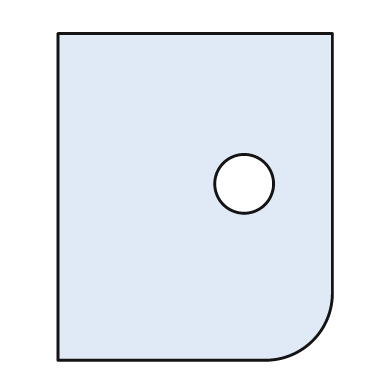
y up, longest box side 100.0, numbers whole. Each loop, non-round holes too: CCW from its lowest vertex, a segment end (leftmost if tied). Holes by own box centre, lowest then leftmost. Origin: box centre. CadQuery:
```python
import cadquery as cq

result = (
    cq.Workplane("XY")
    .moveTo(-42.0, -50.0)
    .lineTo(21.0, -50.0)
    .threePointArc((36.0, -44.0), (42.0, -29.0))
    .lineTo(42.0, 50.0)
    .lineTo(-42.0, 50.0)
    .close()
    .moveTo(15.0, 4.0)
    .circle(9.0)
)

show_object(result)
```